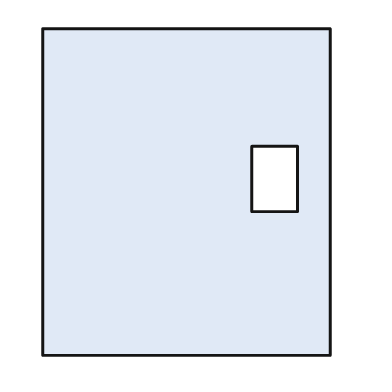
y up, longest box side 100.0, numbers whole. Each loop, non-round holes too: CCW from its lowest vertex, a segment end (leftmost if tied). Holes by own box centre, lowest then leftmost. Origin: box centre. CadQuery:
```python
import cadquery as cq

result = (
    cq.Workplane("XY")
    .moveTo(-44.0, -50.0)
    .lineTo(44.0, -50.0)
    .lineTo(44.0, 50.0)
    .lineTo(-44.0, 50.0)
    .close()
    .moveTo(20.0, -6.0)
    .lineTo(34.0, -6.0)
    .lineTo(34.0, 14.0)
    .lineTo(20.0, 14.0)
    .close()
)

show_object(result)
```